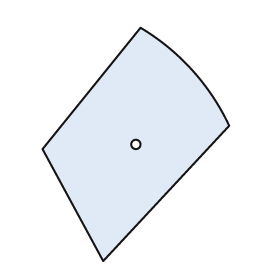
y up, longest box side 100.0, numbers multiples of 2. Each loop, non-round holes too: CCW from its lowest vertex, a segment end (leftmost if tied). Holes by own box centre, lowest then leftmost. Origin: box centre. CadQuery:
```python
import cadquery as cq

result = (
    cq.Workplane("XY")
    .moveTo(-14.0, -50.0)
    .lineTo(40.0, 8.0)
    .threePointArc((24.0, 32.0), (2.0, 50.0))
    .lineTo(-40.0, -2.0)
    .close()
    .moveTo(0.0, 0.0)
    .circle(2.0)
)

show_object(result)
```